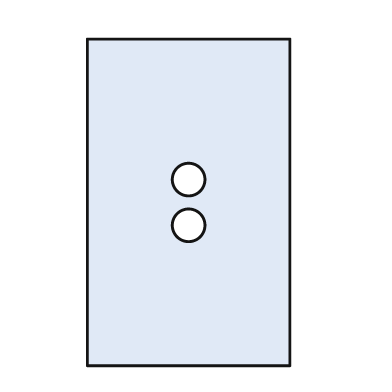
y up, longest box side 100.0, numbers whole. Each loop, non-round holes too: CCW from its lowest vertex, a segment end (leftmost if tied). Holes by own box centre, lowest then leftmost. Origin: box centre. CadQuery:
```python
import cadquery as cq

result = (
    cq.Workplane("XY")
    .moveTo(-31.0, -50.0)
    .lineTo(31.0, -50.0)
    .lineTo(31.0, 50.0)
    .lineTo(-31.0, 50.0)
    .close()
    .moveTo(0.0, -7.0)
    .circle(5.0)
    .moveTo(0.0, 7.0)
    .circle(5.0)
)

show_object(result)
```